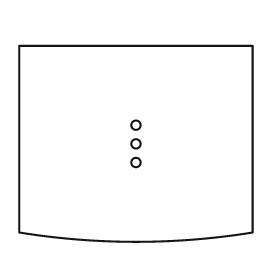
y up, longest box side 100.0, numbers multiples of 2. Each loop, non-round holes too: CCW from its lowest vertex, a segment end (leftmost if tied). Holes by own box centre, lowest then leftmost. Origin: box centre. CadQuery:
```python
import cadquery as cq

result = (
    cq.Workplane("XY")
    .moveTo(-50.0, -38.0)
    .threePointArc((0.0, -42.0), (50.0, -38.0))
    .lineTo(50.0, 42.0)
    .lineTo(-50.0, 42.0)
    .close()
    .moveTo(0.0, -8.0)
    .circle(2.0)
    .moveTo(0.0, 0.0)
    .circle(2.0)
    .moveTo(0.0, 8.0)
    .circle(2.0)
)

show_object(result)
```